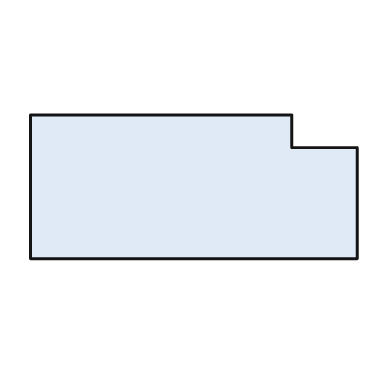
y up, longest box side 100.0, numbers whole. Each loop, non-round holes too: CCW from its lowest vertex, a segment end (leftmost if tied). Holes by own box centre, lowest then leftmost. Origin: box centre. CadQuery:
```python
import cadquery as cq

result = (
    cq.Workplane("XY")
    .moveTo(-50.0, -22.0)
    .lineTo(50.0, -22.0)
    .lineTo(50.0, 12.0)
    .lineTo(30.0, 12.0)
    .lineTo(30.0, 22.0)
    .lineTo(-50.0, 22.0)
    .close()
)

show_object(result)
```